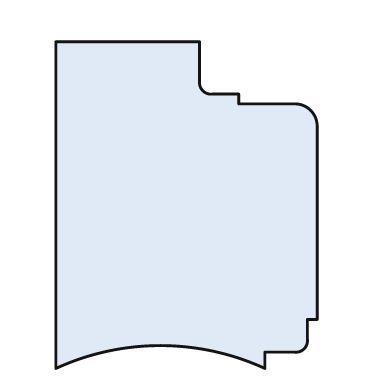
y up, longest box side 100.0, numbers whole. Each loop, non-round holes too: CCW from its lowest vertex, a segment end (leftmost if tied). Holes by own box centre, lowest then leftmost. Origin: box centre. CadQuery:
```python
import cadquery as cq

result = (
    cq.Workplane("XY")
    .moveTo(-40.0, -50.0)
    .threePointArc((-8.0, -43.0), (24.0, -50.0))
    .lineTo(24.0, -45.0)
    .lineTo(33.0, -45.0)
    .threePointArc((36.0, -44.0), (37.0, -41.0))
    .lineTo(37.0, -35.0)
    .lineTo(40.0, -35.0)
    .lineTo(40.0, 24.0)
    .threePointArc((38.0, 29.0), (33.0, 31.0))
    .lineTo(16.0, 31.0)
    .lineTo(16.0, 34.0)
    .lineTo(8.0, 34.0)
    .threePointArc((5.0, 35.0), (4.0, 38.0))
    .lineTo(4.0, 50.0)
    .lineTo(-40.0, 50.0)
    .close()
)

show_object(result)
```